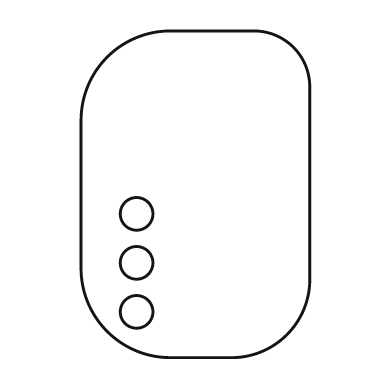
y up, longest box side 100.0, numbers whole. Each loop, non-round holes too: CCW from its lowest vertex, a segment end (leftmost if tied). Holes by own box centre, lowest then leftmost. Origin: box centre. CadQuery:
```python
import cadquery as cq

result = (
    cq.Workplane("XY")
    .moveTo(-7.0, -50.0)
    .lineTo(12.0, -50.0)
    .threePointArc((28.0, -43.0), (35.0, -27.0))
    .lineTo(35.0, 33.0)
    .threePointArc((30.0, 45.0), (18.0, 50.0))
    .lineTo(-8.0, 50.0)
    .threePointArc((-27.0, 42.0), (-35.0, 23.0))
    .lineTo(-35.0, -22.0)
    .threePointArc((-27.0, -42.0), (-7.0, -50.0))
    .close()
    .moveTo(-18.0, -36.0)
    .circle(5.0)
    .moveTo(-18.0, -21.0)
    .circle(5.0)
    .moveTo(-18.0, -6.0)
    .circle(5.0)
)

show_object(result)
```